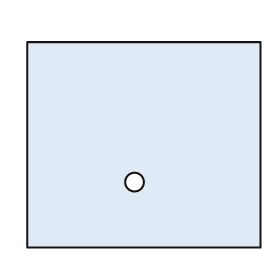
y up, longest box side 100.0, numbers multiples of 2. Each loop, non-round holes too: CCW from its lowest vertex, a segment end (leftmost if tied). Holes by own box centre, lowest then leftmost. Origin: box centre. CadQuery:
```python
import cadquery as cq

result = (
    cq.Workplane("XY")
    .moveTo(-50.0, -44.0)
    .lineTo(50.0, -44.0)
    .lineTo(50.0, 44.0)
    .lineTo(-50.0, 44.0)
    .close()
    .moveTo(-4.0, -16.0)
    .circle(4.0)
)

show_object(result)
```